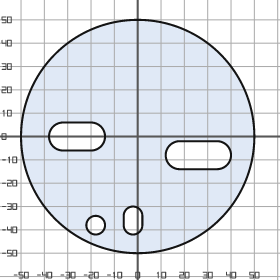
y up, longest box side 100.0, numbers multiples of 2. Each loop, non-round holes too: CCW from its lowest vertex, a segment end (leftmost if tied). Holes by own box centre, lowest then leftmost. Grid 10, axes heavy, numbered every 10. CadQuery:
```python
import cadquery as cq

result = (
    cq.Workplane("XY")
    .moveTo(0.0, 0.0)
    .circle(50.0)
    .moveTo(-18.0, -38.0)
    .circle(4.0)
    .moveTo(-6.0, -38.0)
    .threePointArc((-2.0, -42.0), (2.0, -38.0))
    .lineTo(2.0, -34.0)
    .threePointArc((-2.0, -30.0), (-6.0, -34.0))
    .close()
    .moveTo(18.0, -14.0)
    .lineTo(34.0, -14.0)
    .threePointArc((40.0, -8.0), (34.0, -2.0))
    .lineTo(18.0, -2.0)
    .threePointArc((12.0, -8.0), (18.0, -14.0))
    .close()
    .moveTo(-32.0, -6.0)
    .lineTo(-20.0, -6.0)
    .threePointArc((-14.0, 0.0), (-20.0, 6.0))
    .lineTo(-32.0, 6.0)
    .threePointArc((-38.0, 0.0), (-32.0, -6.0))
    .close()
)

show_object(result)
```